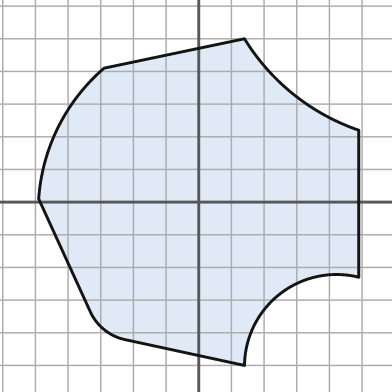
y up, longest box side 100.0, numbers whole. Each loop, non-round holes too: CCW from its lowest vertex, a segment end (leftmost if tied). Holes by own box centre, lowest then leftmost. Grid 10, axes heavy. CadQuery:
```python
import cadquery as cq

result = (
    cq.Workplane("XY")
    .moveTo(14.0, -50.0)
    .threePointArc((25.0, -28.0), (49.0, -23.0))
    .lineTo(49.0, 22.0)
    .threePointArc((29.0, 33.0), (14.0, 50.0))
    .lineTo(-29.0, 41.0)
    .threePointArc((-43.0, 23.0), (-49.0, 1.0))
    .lineTo(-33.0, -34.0)
    .threePointArc((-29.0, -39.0), (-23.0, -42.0))
    .close()
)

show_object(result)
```